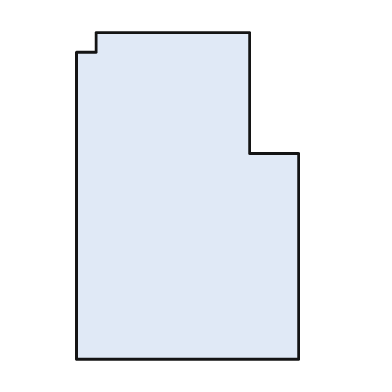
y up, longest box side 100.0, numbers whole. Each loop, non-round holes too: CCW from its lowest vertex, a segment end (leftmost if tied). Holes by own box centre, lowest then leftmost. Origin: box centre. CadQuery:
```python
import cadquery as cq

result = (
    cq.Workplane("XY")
    .moveTo(-34.0, -50.0)
    .lineTo(34.0, -50.0)
    .lineTo(34.0, 13.0)
    .lineTo(19.0, 13.0)
    .lineTo(19.0, 50.0)
    .lineTo(-28.0, 50.0)
    .lineTo(-28.0, 44.0)
    .lineTo(-34.0, 44.0)
    .close()
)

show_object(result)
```